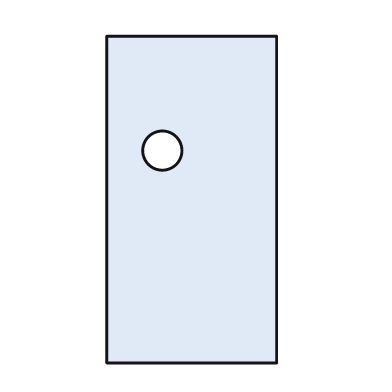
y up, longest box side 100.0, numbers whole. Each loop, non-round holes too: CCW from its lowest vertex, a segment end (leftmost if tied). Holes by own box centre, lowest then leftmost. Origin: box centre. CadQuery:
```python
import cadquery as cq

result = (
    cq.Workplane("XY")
    .moveTo(-26.0, -50.0)
    .lineTo(26.0, -50.0)
    .lineTo(26.0, 50.0)
    .lineTo(-26.0, 50.0)
    .close()
    .moveTo(-9.0, 15.0)
    .circle(6.0)
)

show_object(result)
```